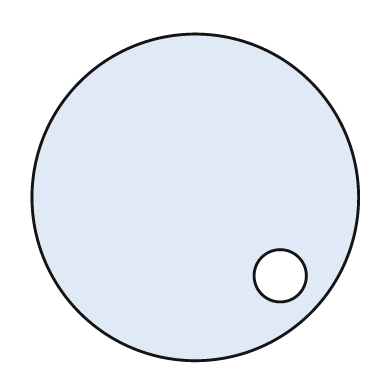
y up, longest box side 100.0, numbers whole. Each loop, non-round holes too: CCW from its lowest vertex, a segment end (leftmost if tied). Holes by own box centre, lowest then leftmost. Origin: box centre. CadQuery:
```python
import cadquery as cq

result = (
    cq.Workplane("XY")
    .moveTo(0.0, 0.0)
    .circle(50.0)
    .moveTo(26.0, -24.0)
    .circle(8.0)
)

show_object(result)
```